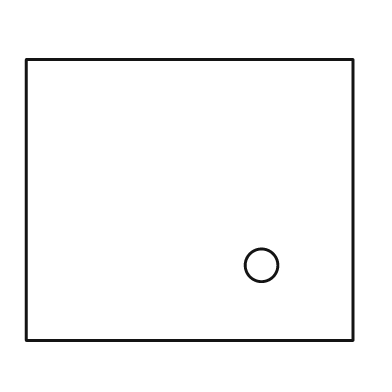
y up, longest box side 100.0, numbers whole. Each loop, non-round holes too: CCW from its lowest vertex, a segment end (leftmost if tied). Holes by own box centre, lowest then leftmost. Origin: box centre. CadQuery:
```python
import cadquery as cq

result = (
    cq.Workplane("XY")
    .moveTo(-50.0, -43.0)
    .lineTo(50.0, -43.0)
    .lineTo(50.0, 43.0)
    .lineTo(-50.0, 43.0)
    .close()
    .moveTo(22.0, -20.0)
    .circle(5.0)
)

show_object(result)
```